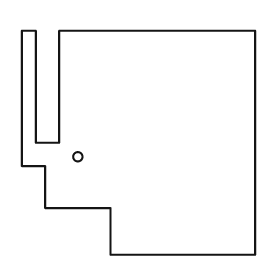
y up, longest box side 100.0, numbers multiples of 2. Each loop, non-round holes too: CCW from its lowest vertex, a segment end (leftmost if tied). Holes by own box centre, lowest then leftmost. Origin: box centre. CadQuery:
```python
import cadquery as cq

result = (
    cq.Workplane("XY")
    .moveTo(-12.0, -48.0)
    .lineTo(50.0, -48.0)
    .lineTo(50.0, 48.0)
    .lineTo(-34.0, 48.0)
    .lineTo(-34.0, 0.0)
    .lineTo(-44.0, 0.0)
    .lineTo(-44.0, 48.0)
    .lineTo(-50.0, 48.0)
    .lineTo(-50.0, -10.0)
    .lineTo(-40.0, -10.0)
    .lineTo(-40.0, -28.0)
    .lineTo(-12.0, -28.0)
    .close()
    .moveTo(-26.0, -6.0)
    .circle(2.0)
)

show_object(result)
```